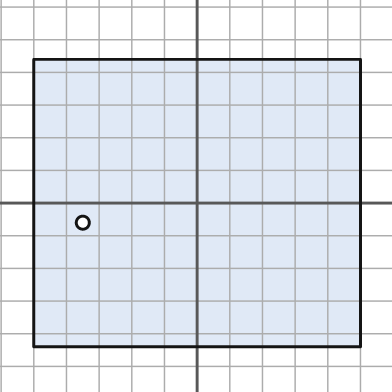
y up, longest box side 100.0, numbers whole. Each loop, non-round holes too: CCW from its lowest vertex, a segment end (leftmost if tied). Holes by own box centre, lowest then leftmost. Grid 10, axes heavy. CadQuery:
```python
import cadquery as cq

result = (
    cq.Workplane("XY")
    .moveTo(-50.0, -44.0)
    .lineTo(50.0, -44.0)
    .lineTo(50.0, 44.0)
    .lineTo(-50.0, 44.0)
    .close()
    .moveTo(-35.0, -6.0)
    .circle(2.0)
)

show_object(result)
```